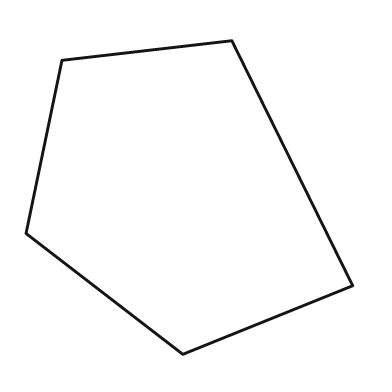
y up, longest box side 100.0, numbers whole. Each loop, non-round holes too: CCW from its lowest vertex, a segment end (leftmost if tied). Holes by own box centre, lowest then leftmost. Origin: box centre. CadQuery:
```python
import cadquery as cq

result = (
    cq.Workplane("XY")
    .moveTo(-2.0, -48.0)
    .lineTo(50.0, -27.0)
    .lineTo(13.0, 48.0)
    .lineTo(-39.0, 42.0)
    .lineTo(-50.0, -11.0)
    .close()
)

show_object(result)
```